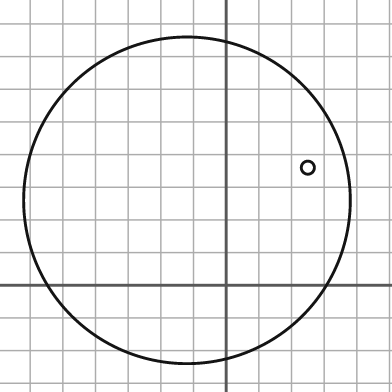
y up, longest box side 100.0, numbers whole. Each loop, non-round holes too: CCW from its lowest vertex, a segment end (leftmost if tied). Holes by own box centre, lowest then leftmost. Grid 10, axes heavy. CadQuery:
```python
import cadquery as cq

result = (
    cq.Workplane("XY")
    .moveTo(-12.0, 26.0)
    .circle(50.0)
    .moveTo(25.0, 36.0)
    .circle(2.0)
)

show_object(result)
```